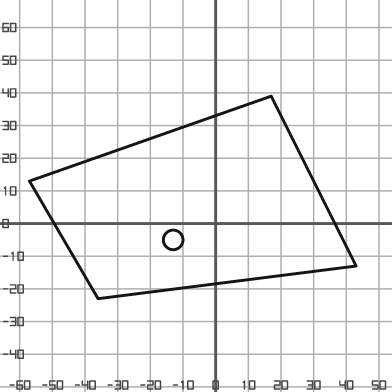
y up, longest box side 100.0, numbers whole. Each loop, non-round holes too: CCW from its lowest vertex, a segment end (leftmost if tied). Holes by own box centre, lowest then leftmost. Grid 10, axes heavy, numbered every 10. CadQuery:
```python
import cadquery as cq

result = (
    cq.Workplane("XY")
    .moveTo(-36.0, -23.0)
    .lineTo(43.0, -13.0)
    .lineTo(17.0, 39.0)
    .lineTo(-57.0, 13.0)
    .close()
    .moveTo(-13.0, -5.0)
    .circle(3.0)
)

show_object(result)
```